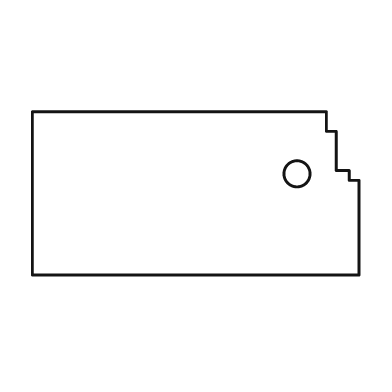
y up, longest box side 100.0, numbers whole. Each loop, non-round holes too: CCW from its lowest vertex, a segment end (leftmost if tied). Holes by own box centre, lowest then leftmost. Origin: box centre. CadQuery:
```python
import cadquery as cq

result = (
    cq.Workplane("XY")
    .moveTo(-50.0, -25.0)
    .lineTo(50.0, -25.0)
    .lineTo(50.0, 4.0)
    .lineTo(47.0, 4.0)
    .lineTo(47.0, 7.0)
    .lineTo(43.0, 7.0)
    .lineTo(43.0, 19.0)
    .lineTo(40.0, 19.0)
    .lineTo(40.0, 25.0)
    .lineTo(-50.0, 25.0)
    .close()
    .moveTo(31.0, 6.0)
    .circle(4.0)
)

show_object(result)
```